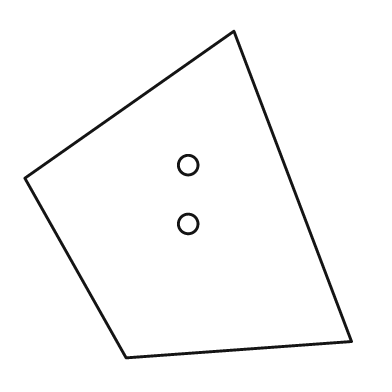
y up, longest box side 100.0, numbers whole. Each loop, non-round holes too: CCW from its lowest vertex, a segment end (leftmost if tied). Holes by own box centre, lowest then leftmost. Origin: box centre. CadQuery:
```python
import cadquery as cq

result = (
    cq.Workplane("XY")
    .moveTo(-19.0, -50.0)
    .lineTo(50.0, -45.0)
    .lineTo(14.0, 50.0)
    .lineTo(-50.0, 5.0)
    .close()
    .moveTo(0.0, -9.0)
    .circle(3.0)
    .moveTo(0.0, 9.0)
    .circle(3.0)
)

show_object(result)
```